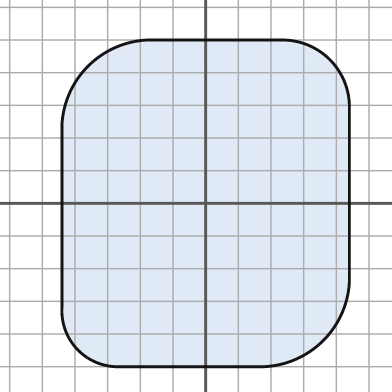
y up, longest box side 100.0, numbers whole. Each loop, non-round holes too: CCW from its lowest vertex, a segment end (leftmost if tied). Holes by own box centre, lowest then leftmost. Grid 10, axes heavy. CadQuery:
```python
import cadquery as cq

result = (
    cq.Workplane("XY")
    .moveTo(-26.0, -50.0)
    .lineTo(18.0, -50.0)
    .threePointArc((36.0, -42.0), (44.0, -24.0))
    .lineTo(44.0, 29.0)
    .threePointArc((38.0, 44.0), (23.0, 50.0))
    .lineTo(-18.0, 50.0)
    .threePointArc((-36.0, 42.0), (-44.0, 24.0))
    .lineTo(-44.0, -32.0)
    .threePointArc((-39.0, -45.0), (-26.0, -50.0))
    .close()
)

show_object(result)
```